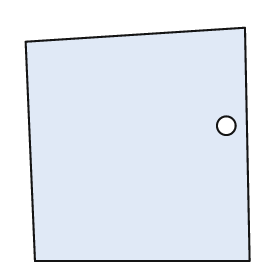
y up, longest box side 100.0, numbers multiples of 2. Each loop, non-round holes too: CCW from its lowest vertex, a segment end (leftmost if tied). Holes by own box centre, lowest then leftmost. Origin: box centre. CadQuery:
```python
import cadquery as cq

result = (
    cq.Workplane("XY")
    .moveTo(-44.0, -50.0)
    .lineTo(48.0, -50.0)
    .lineTo(46.0, 50.0)
    .lineTo(-48.0, 44.0)
    .close()
    .moveTo(38.0, 8.0)
    .circle(4.0)
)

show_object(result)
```